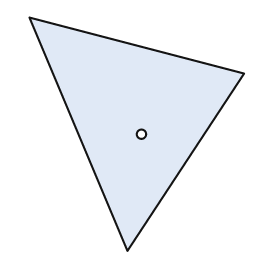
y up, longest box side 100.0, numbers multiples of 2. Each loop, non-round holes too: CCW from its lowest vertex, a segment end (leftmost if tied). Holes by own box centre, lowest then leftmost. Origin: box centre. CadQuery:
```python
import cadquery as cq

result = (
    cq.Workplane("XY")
    .moveTo(-4.0, -50.0)
    .lineTo(46.0, 26.0)
    .lineTo(-46.0, 50.0)
    .close()
    .moveTo(2.0, 0.0)
    .circle(2.0)
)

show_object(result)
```